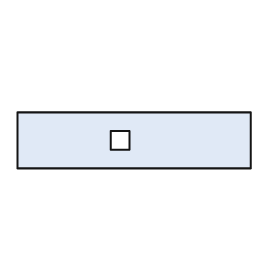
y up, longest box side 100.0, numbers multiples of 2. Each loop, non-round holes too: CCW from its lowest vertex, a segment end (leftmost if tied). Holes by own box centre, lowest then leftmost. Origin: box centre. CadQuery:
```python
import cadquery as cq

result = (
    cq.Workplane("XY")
    .moveTo(-50.0, -12.0)
    .lineTo(50.0, -12.0)
    .lineTo(50.0, 12.0)
    .lineTo(-50.0, 12.0)
    .close()
    .moveTo(-10.0, -4.0)
    .lineTo(-2.0, -4.0)
    .lineTo(-2.0, 4.0)
    .lineTo(-10.0, 4.0)
    .close()
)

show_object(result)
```